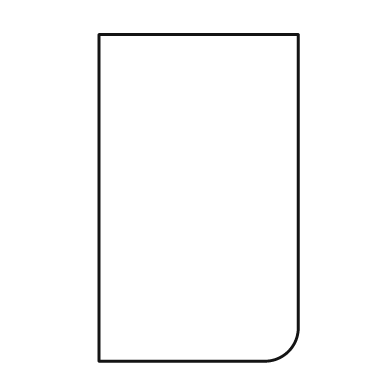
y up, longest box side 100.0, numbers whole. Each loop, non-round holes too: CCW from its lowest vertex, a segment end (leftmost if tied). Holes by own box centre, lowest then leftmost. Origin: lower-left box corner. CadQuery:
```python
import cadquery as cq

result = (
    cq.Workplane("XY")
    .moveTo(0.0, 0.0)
    .lineTo(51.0, 0.0)
    .threePointArc((58.0, 3.0), (61.0, 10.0))
    .lineTo(61.0, 100.0)
    .lineTo(0.0, 100.0)
    .close()
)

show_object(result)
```